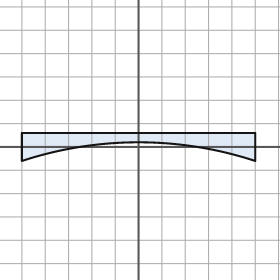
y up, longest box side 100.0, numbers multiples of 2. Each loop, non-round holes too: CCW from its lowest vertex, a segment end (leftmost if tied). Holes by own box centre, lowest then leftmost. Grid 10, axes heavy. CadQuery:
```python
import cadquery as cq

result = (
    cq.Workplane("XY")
    .moveTo(-50.0, -6.0)
    .threePointArc((0.0, 2.0), (50.0, -6.0))
    .lineTo(50.0, 6.0)
    .lineTo(-50.0, 6.0)
    .close()
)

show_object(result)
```